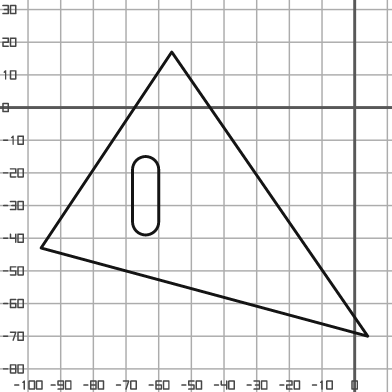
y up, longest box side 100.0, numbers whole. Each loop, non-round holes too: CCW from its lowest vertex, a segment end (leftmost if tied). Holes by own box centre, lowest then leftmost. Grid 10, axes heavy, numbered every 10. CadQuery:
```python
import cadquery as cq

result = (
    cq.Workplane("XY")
    .moveTo(4.0, -70.0)
    .lineTo(-56.0, 17.0)
    .lineTo(-96.0, -43.0)
    .close()
    .moveTo(-68.0, -35.0)
    .threePointArc((-64.0, -39.0), (-60.0, -35.0))
    .lineTo(-60.0, -19.0)
    .threePointArc((-64.0, -15.0), (-68.0, -19.0))
    .close()
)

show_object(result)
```